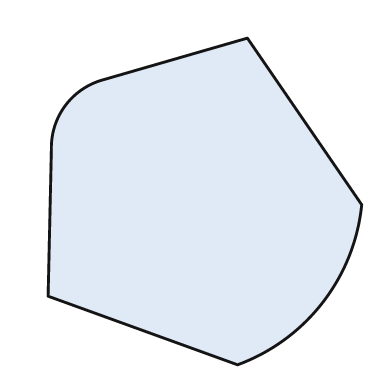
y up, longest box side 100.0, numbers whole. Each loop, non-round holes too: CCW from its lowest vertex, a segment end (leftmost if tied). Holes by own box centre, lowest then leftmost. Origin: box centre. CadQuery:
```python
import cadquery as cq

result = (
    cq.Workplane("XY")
    .moveTo(10.0, -50.0)
    .threePointArc((36.0, -31.0), (48.0, -1.0))
    .lineTo(13.0, 50.0)
    .lineTo(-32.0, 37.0)
    .threePointArc((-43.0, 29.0), (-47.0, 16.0))
    .lineTo(-48.0, -29.0)
    .close()
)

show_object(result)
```